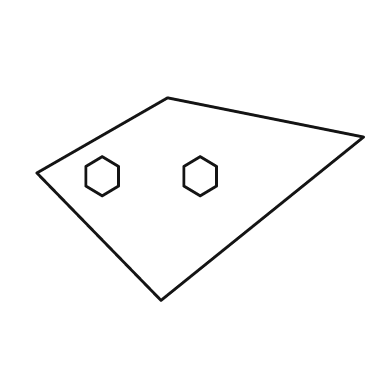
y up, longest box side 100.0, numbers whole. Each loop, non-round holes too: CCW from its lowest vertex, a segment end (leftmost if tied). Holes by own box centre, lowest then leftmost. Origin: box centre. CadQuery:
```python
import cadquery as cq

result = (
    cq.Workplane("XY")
    .moveTo(-12.0, -31.0)
    .lineTo(50.0, 19.0)
    .lineTo(-10.0, 31.0)
    .lineTo(-50.0, 8.0)
    .close()
    .moveTo(-30.0, 1.0)
    .lineTo(-25.0, 4.0)
    .lineTo(-25.0, 10.0)
    .lineTo(-30.0, 13.0)
    .lineTo(-35.0, 10.0)
    .lineTo(-35.0, 4.0)
    .close()
    .moveTo(0.0, 1.0)
    .lineTo(5.0, 4.0)
    .lineTo(5.0, 10.0)
    .lineTo(0.0, 13.0)
    .lineTo(-5.0, 10.0)
    .lineTo(-5.0, 4.0)
    .close()
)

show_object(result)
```